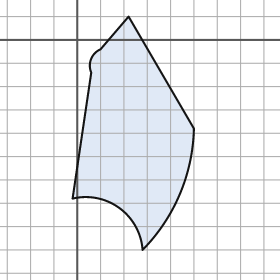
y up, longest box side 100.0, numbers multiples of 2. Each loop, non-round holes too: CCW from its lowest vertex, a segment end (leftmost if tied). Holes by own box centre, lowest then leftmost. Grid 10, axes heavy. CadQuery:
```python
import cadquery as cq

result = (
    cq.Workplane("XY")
    .moveTo(28.0, -90.0)
    .threePointArc((44.0, -66.0), (50.0, -38.0))
    .lineTo(22.0, 10.0)
    .lineTo(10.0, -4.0)
    .threePointArc((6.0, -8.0), (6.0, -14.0))
    .lineTo(-2.0, -68.0)
    .threePointArc((18.0, -72.0), (28.0, -90.0))
    .close()
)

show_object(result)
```